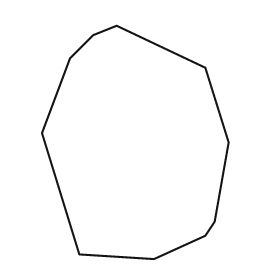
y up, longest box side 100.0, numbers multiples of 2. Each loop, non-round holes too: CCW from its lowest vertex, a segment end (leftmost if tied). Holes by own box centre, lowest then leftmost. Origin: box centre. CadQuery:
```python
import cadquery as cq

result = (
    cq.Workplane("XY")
    .moveTo(8.0, -50.0)
    .lineTo(30.0, -40.0)
    .lineTo(34.0, -34.0)
    .lineTo(40.0, 0.0)
    .lineTo(30.0, 32.0)
    .lineTo(-8.0, 50.0)
    .lineTo(-18.0, 46.0)
    .lineTo(-28.0, 36.0)
    .lineTo(-40.0, 4.0)
    .lineTo(-24.0, -48.0)
    .close()
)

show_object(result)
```